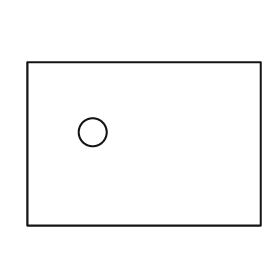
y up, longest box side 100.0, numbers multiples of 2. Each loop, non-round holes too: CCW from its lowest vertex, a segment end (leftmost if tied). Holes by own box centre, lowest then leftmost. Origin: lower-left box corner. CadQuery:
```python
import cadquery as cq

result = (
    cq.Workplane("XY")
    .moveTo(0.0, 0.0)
    .lineTo(100.0, 0.0)
    .lineTo(100.0, 70.0)
    .lineTo(0.0, 70.0)
    .close()
    .moveTo(28.0, 40.0)
    .circle(6.0)
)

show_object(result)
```